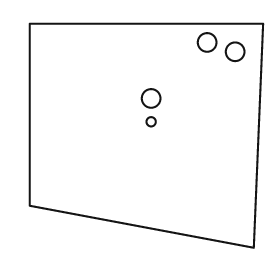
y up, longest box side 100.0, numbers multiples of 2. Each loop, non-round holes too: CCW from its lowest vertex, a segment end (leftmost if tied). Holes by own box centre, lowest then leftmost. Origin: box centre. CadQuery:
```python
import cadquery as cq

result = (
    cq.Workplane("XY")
    .moveTo(46.0, -48.0)
    .lineTo(50.0, 48.0)
    .lineTo(-50.0, 48.0)
    .lineTo(-50.0, -30.0)
    .close()
    .moveTo(2.0, 6.0)
    .circle(2.0)
    .moveTo(2.0, 16.0)
    .circle(4.0)
    .moveTo(38.0, 36.0)
    .circle(4.0)
    .moveTo(26.0, 40.0)
    .circle(4.0)
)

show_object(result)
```